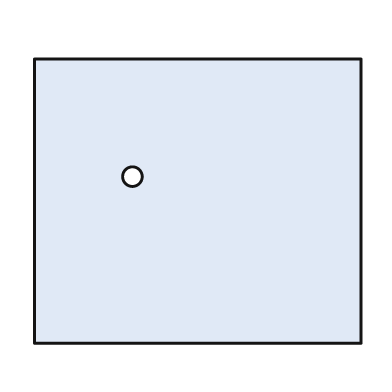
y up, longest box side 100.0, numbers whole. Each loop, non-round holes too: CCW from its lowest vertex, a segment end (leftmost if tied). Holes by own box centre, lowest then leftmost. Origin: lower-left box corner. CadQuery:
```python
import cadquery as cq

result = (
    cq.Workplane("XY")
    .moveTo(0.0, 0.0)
    .lineTo(100.0, 0.0)
    .lineTo(100.0, 87.0)
    .lineTo(0.0, 87.0)
    .close()
    .moveTo(30.0, 51.0)
    .circle(3.0)
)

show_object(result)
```